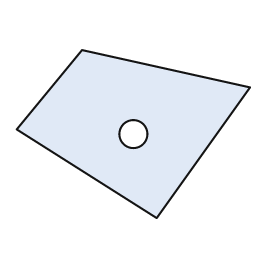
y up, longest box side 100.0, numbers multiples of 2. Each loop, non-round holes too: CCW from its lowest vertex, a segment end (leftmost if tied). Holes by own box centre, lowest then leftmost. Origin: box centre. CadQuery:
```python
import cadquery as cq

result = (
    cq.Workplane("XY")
    .moveTo(10.0, -36.0)
    .lineTo(50.0, 20.0)
    .lineTo(-22.0, 36.0)
    .lineTo(-50.0, 2.0)
    .close()
    .moveTo(0.0, 0.0)
    .circle(6.0)
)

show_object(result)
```